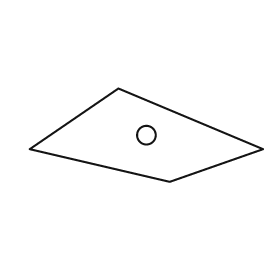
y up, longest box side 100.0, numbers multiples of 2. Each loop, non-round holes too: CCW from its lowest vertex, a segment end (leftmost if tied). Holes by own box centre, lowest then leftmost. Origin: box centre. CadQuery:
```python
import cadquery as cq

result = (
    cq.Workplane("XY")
    .moveTo(10.0, -20.0)
    .lineTo(50.0, -6.0)
    .lineTo(-12.0, 20.0)
    .lineTo(-50.0, -6.0)
    .close()
    .moveTo(0.0, 0.0)
    .circle(4.0)
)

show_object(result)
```